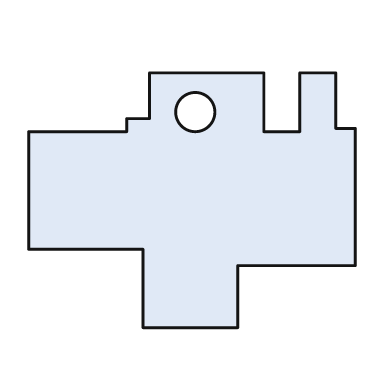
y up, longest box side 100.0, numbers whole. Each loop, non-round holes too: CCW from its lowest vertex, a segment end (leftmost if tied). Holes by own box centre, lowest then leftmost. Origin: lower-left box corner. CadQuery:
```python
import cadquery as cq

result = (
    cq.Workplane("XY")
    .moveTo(35.0, 0.0)
    .lineTo(64.0, 0.0)
    .lineTo(64.0, 19.0)
    .lineTo(100.0, 19.0)
    .lineTo(100.0, 61.0)
    .lineTo(94.0, 61.0)
    .lineTo(94.0, 78.0)
    .lineTo(83.0, 78.0)
    .lineTo(83.0, 60.0)
    .lineTo(72.0, 60.0)
    .lineTo(72.0, 78.0)
    .lineTo(37.0, 78.0)
    .lineTo(37.0, 64.0)
    .lineTo(30.0, 64.0)
    .lineTo(30.0, 60.0)
    .lineTo(0.0, 60.0)
    .lineTo(0.0, 24.0)
    .lineTo(35.0, 24.0)
    .close()
    .moveTo(51.0, 66.0)
    .circle(6.0)
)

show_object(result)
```